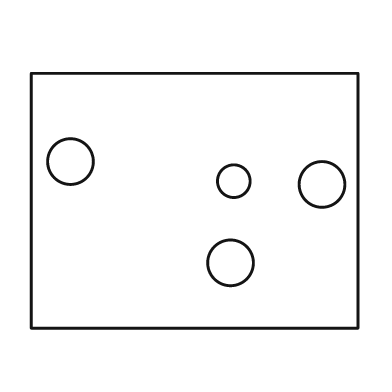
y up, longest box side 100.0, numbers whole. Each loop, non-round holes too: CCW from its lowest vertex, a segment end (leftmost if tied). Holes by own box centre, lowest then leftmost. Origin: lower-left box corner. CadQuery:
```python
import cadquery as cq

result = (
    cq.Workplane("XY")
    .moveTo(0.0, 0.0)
    .lineTo(100.0, 0.0)
    .lineTo(100.0, 78.0)
    .lineTo(0.0, 78.0)
    .close()
    .moveTo(61.0, 20.0)
    .circle(7.0)
    .moveTo(89.0, 44.0)
    .circle(7.0)
    .moveTo(62.0, 45.0)
    .circle(5.0)
    .moveTo(12.0, 51.0)
    .circle(7.0)
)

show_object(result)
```